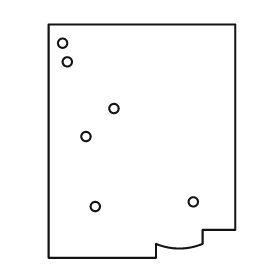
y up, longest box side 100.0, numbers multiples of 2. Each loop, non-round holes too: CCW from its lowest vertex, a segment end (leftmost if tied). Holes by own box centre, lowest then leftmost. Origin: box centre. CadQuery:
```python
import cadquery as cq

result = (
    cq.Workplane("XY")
    .moveTo(-40.0, -50.0)
    .lineTo(6.0, -50.0)
    .lineTo(6.0, -44.0)
    .threePointArc((16.0, -46.0), (26.0, -44.0))
    .lineTo(26.0, -38.0)
    .lineTo(40.0, -38.0)
    .lineTo(40.0, 50.0)
    .lineTo(-40.0, 50.0)
    .close()
    .moveTo(-20.0, -28.0)
    .circle(2.0)
    .moveTo(22.0, -26.0)
    .circle(2.0)
    .moveTo(-24.0, 2.0)
    .circle(2.0)
    .moveTo(-12.0, 14.0)
    .circle(2.0)
    .moveTo(-32.0, 34.0)
    .circle(2.0)
    .moveTo(-34.0, 42.0)
    .circle(2.0)
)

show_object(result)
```